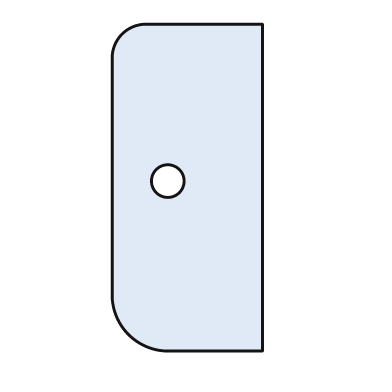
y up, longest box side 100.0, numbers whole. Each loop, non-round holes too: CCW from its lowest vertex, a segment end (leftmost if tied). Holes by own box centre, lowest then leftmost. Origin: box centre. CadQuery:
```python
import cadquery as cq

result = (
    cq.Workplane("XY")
    .moveTo(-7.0, -50.0)
    .lineTo(23.0, -50.0)
    .lineTo(23.0, 50.0)
    .lineTo(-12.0, 50.0)
    .threePointArc((-20.0, 47.0), (-23.0, 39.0))
    .lineTo(-23.0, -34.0)
    .threePointArc((-18.0, -45.0), (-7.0, -50.0))
    .close()
    .moveTo(-6.0, 2.0)
    .circle(5.0)
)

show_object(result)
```